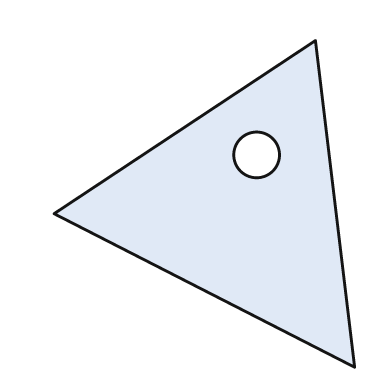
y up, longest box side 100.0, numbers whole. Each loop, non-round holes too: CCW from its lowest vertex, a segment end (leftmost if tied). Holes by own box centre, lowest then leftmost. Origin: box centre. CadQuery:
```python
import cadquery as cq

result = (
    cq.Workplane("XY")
    .moveTo(46.0, -50.0)
    .lineTo(34.0, 50.0)
    .lineTo(-46.0, -3.0)
    .close()
    .moveTo(16.0, 15.0)
    .circle(7.0)
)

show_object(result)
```